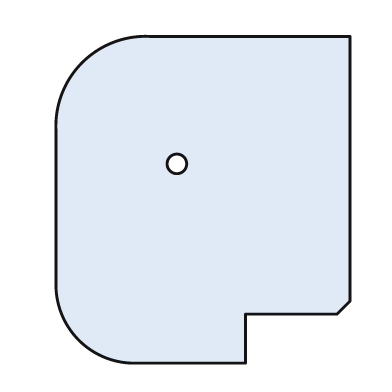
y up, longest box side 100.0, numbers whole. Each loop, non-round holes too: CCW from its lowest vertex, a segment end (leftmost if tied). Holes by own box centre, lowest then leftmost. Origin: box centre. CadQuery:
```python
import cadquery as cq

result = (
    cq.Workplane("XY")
    .moveTo(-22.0, -50.0)
    .lineTo(13.0, -50.0)
    .lineTo(13.0, -35.0)
    .lineTo(41.0, -35.0)
    .lineTo(45.0, -31.0)
    .lineTo(45.0, 50.0)
    .lineTo(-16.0, 50.0)
    .threePointArc((-37.0, 42.0), (-45.0, 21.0))
    .lineTo(-45.0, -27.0)
    .threePointArc((-38.0, -43.0), (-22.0, -50.0))
    .close()
    .moveTo(-8.0, 11.0)
    .circle(3.0)
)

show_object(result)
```